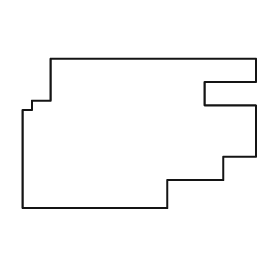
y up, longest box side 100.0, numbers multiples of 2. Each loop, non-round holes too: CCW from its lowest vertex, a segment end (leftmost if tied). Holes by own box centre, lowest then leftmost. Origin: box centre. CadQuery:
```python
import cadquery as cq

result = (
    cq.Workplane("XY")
    .moveTo(-50.0, -32.0)
    .lineTo(12.0, -32.0)
    .lineTo(12.0, -20.0)
    .lineTo(36.0, -20.0)
    .lineTo(36.0, -10.0)
    .lineTo(50.0, -10.0)
    .lineTo(50.0, 12.0)
    .lineTo(28.0, 12.0)
    .lineTo(28.0, 22.0)
    .lineTo(50.0, 22.0)
    .lineTo(50.0, 32.0)
    .lineTo(-38.0, 32.0)
    .lineTo(-38.0, 14.0)
    .lineTo(-46.0, 14.0)
    .lineTo(-46.0, 10.0)
    .lineTo(-50.0, 10.0)
    .close()
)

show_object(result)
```